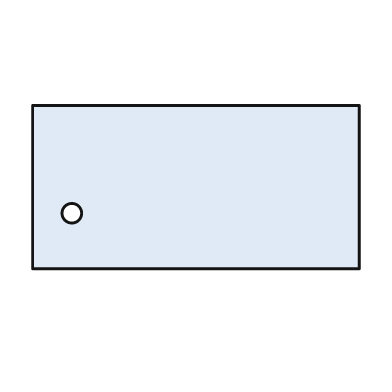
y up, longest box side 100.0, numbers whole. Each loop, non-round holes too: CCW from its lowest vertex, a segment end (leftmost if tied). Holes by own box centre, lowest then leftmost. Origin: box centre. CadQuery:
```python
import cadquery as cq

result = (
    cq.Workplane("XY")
    .moveTo(-50.0, -25.0)
    .lineTo(50.0, -25.0)
    .lineTo(50.0, 25.0)
    .lineTo(-50.0, 25.0)
    .close()
    .moveTo(-38.0, -8.0)
    .circle(3.0)
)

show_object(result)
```